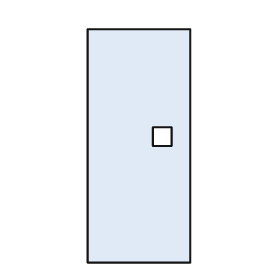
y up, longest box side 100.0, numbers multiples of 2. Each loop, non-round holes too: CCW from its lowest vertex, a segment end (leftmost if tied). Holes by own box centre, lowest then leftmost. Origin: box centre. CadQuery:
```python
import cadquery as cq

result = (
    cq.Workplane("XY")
    .moveTo(-22.0, -50.0)
    .lineTo(22.0, -50.0)
    .lineTo(22.0, 50.0)
    .lineTo(-22.0, 50.0)
    .close()
    .moveTo(6.0, 0.0)
    .lineTo(14.0, 0.0)
    .lineTo(14.0, 8.0)
    .lineTo(6.0, 8.0)
    .close()
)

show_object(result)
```